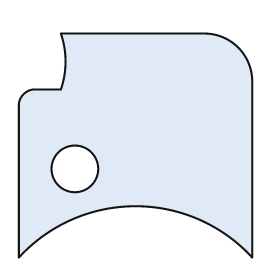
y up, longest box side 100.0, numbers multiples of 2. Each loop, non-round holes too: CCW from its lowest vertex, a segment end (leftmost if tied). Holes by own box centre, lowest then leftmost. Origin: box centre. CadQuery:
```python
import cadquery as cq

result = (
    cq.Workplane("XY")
    .moveTo(-50.0, -48.0)
    .threePointArc((0.0, -26.0), (50.0, -48.0))
    .lineTo(50.0, 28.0)
    .threePointArc((44.0, 42.0), (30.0, 48.0))
    .lineTo(-32.0, 48.0)
    .threePointArc((-30.0, 36.0), (-32.0, 24.0))
    .lineTo(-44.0, 24.0)
    .threePointArc((-48.0, 22.0), (-50.0, 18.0))
    .close()
    .moveTo(-26.0, -10.0)
    .circle(10.0)
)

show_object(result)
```